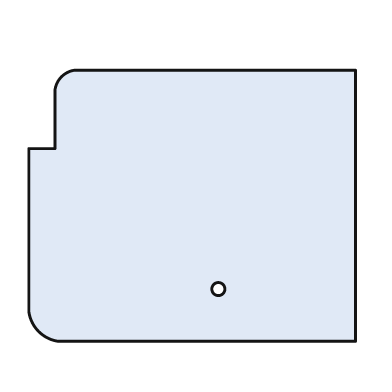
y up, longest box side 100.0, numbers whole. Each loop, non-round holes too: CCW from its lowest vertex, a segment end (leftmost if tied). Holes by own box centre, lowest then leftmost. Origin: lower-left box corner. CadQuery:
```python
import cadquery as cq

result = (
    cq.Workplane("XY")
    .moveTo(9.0, 0.0)
    .lineTo(100.0, 0.0)
    .lineTo(100.0, 83.0)
    .lineTo(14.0, 83.0)
    .threePointArc((10.0, 81.0), (8.0, 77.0))
    .lineTo(8.0, 59.0)
    .lineTo(0.0, 59.0)
    .lineTo(0.0, 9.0)
    .threePointArc((3.0, 3.0), (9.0, 0.0))
    .close()
    .moveTo(58.0, 16.0)
    .circle(2.0)
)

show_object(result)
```